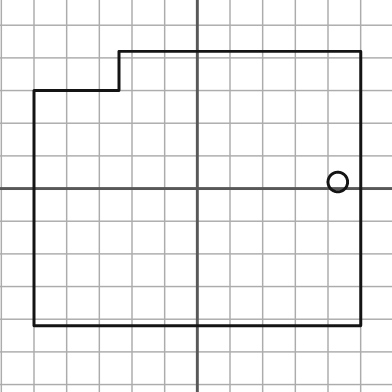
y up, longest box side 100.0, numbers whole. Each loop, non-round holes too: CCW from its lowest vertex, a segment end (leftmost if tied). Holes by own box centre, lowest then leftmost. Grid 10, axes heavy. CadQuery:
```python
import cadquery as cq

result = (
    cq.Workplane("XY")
    .moveTo(-50.0, -42.0)
    .lineTo(50.0, -42.0)
    .lineTo(50.0, 42.0)
    .lineTo(-24.0, 42.0)
    .lineTo(-24.0, 30.0)
    .lineTo(-50.0, 30.0)
    .close()
    .moveTo(43.0, 2.0)
    .circle(3.0)
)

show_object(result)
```